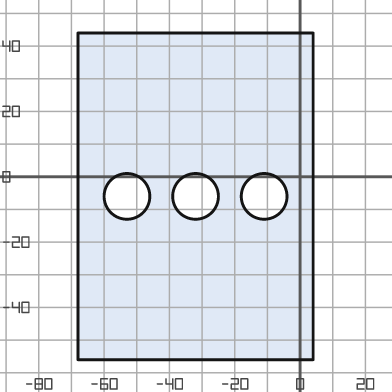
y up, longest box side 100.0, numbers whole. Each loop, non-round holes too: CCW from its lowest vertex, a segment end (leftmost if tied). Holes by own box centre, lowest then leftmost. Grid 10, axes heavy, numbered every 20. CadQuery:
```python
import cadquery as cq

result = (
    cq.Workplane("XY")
    .moveTo(-68.0, -56.0)
    .lineTo(4.0, -56.0)
    .lineTo(4.0, 44.0)
    .lineTo(-68.0, 44.0)
    .close()
    .moveTo(-53.0, -6.0)
    .circle(7.0)
    .moveTo(-32.0, -6.0)
    .circle(7.0)
    .moveTo(-11.0, -6.0)
    .circle(7.0)
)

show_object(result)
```